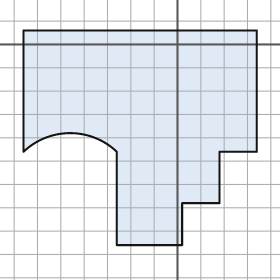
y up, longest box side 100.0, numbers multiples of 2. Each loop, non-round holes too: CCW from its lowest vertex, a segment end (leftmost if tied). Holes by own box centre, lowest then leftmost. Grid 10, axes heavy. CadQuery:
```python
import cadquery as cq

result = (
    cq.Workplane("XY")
    .moveTo(-26.0, -86.0)
    .lineTo(2.0, -86.0)
    .lineTo(2.0, -68.0)
    .lineTo(18.0, -68.0)
    .lineTo(18.0, -46.0)
    .lineTo(34.0, -46.0)
    .lineTo(34.0, 6.0)
    .lineTo(-66.0, 6.0)
    .lineTo(-66.0, -46.0)
    .threePointArc((-46.0, -38.0), (-26.0, -46.0))
    .close()
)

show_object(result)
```